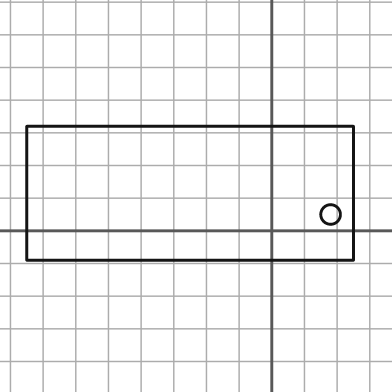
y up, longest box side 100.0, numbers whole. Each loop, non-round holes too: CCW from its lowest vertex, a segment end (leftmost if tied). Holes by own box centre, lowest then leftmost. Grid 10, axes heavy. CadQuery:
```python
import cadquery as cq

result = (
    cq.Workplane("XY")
    .moveTo(-75.0, -9.0)
    .lineTo(25.0, -9.0)
    .lineTo(25.0, 32.0)
    .lineTo(-75.0, 32.0)
    .close()
    .moveTo(18.0, 5.0)
    .circle(3.0)
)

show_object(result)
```